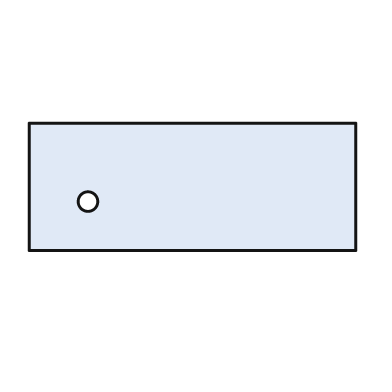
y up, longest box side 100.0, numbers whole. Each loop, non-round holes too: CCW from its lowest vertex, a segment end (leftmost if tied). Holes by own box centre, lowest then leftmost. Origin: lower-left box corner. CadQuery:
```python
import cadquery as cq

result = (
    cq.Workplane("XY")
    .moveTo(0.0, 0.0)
    .lineTo(100.0, 0.0)
    .lineTo(100.0, 39.0)
    .lineTo(0.0, 39.0)
    .close()
    .moveTo(18.0, 15.0)
    .circle(3.0)
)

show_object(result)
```